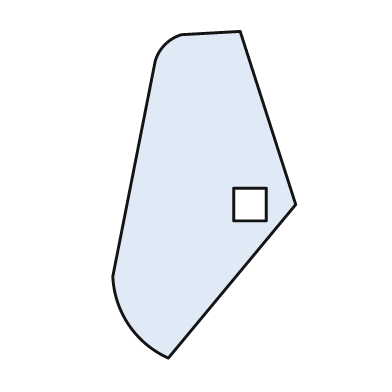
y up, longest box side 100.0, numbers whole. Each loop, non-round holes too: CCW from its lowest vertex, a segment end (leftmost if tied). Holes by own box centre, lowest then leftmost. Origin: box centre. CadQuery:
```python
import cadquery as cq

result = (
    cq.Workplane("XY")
    .moveTo(-11.0, -50.0)
    .lineTo(28.0, -3.0)
    .lineTo(11.0, 50.0)
    .lineTo(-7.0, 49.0)
    .threePointArc((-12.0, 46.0), (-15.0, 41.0))
    .lineTo(-28.0, -25.0)
    .threePointArc((-23.0, -40.0), (-11.0, -50.0))
    .close()
    .moveTo(9.0, -8.0)
    .lineTo(19.0, -8.0)
    .lineTo(19.0, 2.0)
    .lineTo(9.0, 2.0)
    .close()
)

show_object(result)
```